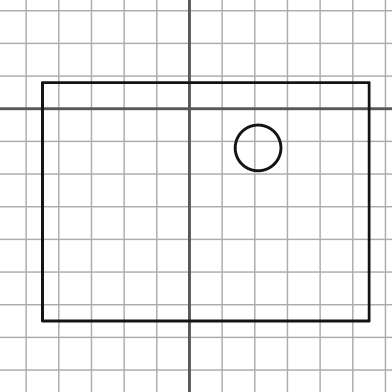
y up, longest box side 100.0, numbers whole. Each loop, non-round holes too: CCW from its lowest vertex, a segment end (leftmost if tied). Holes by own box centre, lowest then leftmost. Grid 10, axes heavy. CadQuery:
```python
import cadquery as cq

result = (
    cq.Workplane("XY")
    .moveTo(-45.0, -65.0)
    .lineTo(55.0, -65.0)
    .lineTo(55.0, 8.0)
    .lineTo(-45.0, 8.0)
    .close()
    .moveTo(21.0, -12.0)
    .circle(7.0)
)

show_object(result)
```